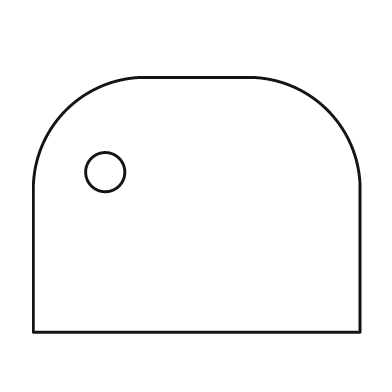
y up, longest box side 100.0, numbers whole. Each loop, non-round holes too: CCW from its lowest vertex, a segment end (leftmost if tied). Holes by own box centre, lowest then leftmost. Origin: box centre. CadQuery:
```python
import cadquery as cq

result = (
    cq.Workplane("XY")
    .moveTo(-50.0, -39.0)
    .lineTo(50.0, -39.0)
    .lineTo(50.0, 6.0)
    .threePointArc((40.0, 29.0), (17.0, 39.0))
    .lineTo(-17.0, 39.0)
    .threePointArc((-40.0, 29.0), (-50.0, 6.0))
    .close()
    .moveTo(-28.0, 10.0)
    .circle(6.0)
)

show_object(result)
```